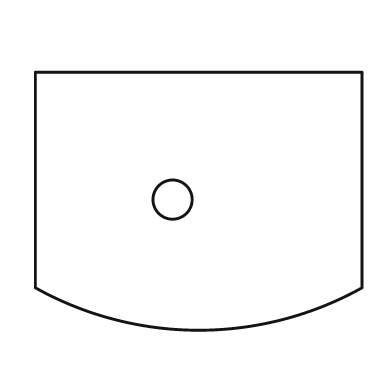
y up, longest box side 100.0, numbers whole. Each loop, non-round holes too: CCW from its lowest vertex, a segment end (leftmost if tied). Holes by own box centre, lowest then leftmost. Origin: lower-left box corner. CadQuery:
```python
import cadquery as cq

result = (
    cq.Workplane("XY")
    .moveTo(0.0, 13.0)
    .threePointArc((50.0, 0.0), (100.0, 13.0))
    .lineTo(100.0, 79.0)
    .lineTo(0.0, 79.0)
    .close()
    .moveTo(42.0, 40.0)
    .circle(6.0)
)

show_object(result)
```